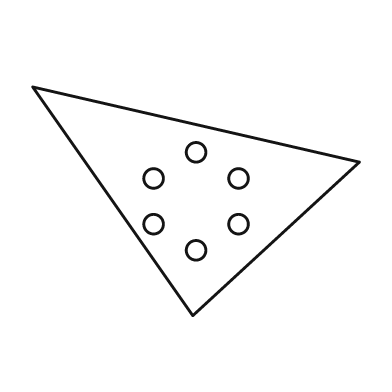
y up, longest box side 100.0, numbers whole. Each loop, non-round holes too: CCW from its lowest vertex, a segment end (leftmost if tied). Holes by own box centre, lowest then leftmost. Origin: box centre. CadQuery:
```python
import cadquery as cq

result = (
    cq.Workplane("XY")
    .moveTo(-1.0, -35.0)
    .lineTo(50.0, 12.0)
    .lineTo(-50.0, 35.0)
    .close()
    .moveTo(0.0, -15.0)
    .circle(3.0)
    .moveTo(-13.0, -7.0)
    .circle(3.0)
    .moveTo(13.0, -7.0)
    .circle(3.0)
    .moveTo(-13.0, 7.0)
    .circle(3.0)
    .moveTo(13.0, 7.0)
    .circle(3.0)
    .moveTo(0.0, 15.0)
    .circle(3.0)
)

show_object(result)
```